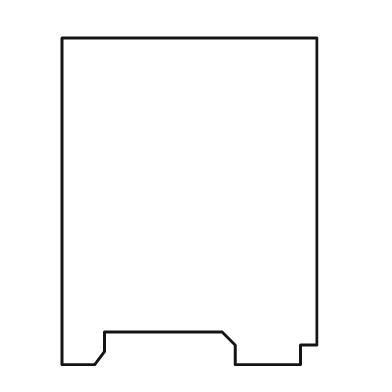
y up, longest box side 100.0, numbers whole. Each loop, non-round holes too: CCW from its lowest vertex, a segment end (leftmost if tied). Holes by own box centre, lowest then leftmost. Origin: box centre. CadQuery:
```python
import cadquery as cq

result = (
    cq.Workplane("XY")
    .moveTo(-39.0, -50.0)
    .lineTo(-29.0, -50.0)
    .lineTo(-26.0, -46.0)
    .lineTo(-26.0, -40.0)
    .lineTo(10.0, -40.0)
    .lineTo(14.0, -44.0)
    .lineTo(14.0, -50.0)
    .lineTo(34.0, -50.0)
    .lineTo(34.0, -44.0)
    .lineTo(39.0, -44.0)
    .lineTo(39.0, 50.0)
    .lineTo(-39.0, 50.0)
    .close()
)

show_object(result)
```